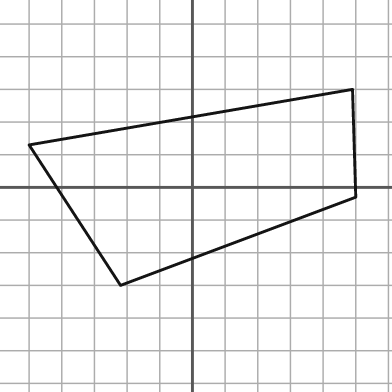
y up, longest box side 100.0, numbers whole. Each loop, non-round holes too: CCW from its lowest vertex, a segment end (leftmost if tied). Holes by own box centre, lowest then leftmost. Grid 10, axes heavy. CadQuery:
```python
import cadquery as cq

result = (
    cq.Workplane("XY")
    .moveTo(-22.0, -30.0)
    .lineTo(50.0, -3.0)
    .lineTo(49.0, 30.0)
    .lineTo(-50.0, 13.0)
    .close()
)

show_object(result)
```